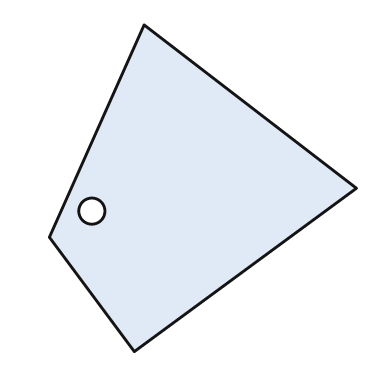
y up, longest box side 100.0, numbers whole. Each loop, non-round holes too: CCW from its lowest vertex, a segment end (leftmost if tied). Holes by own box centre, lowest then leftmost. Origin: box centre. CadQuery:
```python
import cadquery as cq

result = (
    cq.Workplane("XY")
    .moveTo(-21.0, -50.0)
    .lineTo(47.0, 0.0)
    .lineTo(-18.0, 50.0)
    .lineTo(-47.0, -15.0)
    .close()
    .moveTo(-34.0, -7.0)
    .circle(4.0)
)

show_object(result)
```